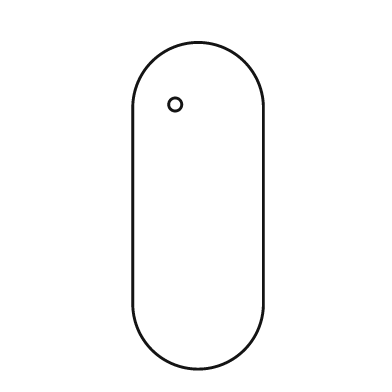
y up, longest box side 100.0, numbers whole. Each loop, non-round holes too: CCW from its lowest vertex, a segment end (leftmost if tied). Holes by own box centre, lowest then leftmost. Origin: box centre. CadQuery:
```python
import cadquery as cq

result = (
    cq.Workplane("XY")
    .moveTo(-20.0, -30.0)
    .threePointArc((0.0, -50.0), (20.0, -30.0))
    .lineTo(20.0, 30.0)
    .threePointArc((0.0, 50.0), (-20.0, 30.0))
    .close()
    .moveTo(-7.0, 31.0)
    .circle(2.0)
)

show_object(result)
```